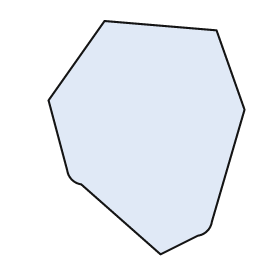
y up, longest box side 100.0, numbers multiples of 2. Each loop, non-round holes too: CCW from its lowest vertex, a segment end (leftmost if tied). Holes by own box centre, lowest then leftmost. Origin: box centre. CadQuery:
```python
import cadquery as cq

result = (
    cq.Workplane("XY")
    .moveTo(6.0, -50.0)
    .lineTo(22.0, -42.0)
    .threePointArc((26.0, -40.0), (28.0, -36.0))
    .lineTo(42.0, 12.0)
    .lineTo(30.0, 46.0)
    .lineTo(-18.0, 50.0)
    .lineTo(-42.0, 16.0)
    .lineTo(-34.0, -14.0)
    .threePointArc((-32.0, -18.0), (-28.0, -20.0))
    .close()
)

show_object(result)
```